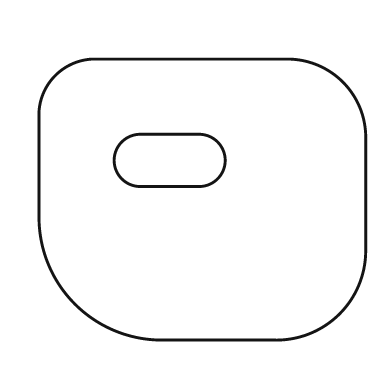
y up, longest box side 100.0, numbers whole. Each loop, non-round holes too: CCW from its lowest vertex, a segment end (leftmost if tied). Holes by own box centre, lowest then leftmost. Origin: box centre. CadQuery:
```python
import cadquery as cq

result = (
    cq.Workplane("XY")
    .moveTo(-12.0, -43.0)
    .lineTo(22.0, -43.0)
    .threePointArc((42.0, -35.0), (50.0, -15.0))
    .lineTo(50.0, 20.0)
    .threePointArc((43.0, 36.0), (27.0, 43.0))
    .lineTo(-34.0, 43.0)
    .threePointArc((-45.0, 38.0), (-50.0, 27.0))
    .lineTo(-50.0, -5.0)
    .threePointArc((-39.0, -32.0), (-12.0, -43.0))
    .close()
    .moveTo(-19.0, 4.0)
    .lineTo(-1.0, 4.0)
    .threePointArc((7.0, 12.0), (-1.0, 20.0))
    .lineTo(-19.0, 20.0)
    .threePointArc((-27.0, 12.0), (-19.0, 4.0))
    .close()
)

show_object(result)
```